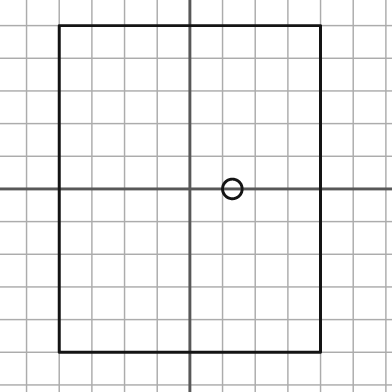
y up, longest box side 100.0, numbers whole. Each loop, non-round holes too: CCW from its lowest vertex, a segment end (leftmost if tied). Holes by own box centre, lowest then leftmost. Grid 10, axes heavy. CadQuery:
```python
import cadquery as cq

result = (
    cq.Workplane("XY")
    .moveTo(-40.0, -50.0)
    .lineTo(40.0, -50.0)
    .lineTo(40.0, 50.0)
    .lineTo(-40.0, 50.0)
    .close()
    .moveTo(13.0, 0.0)
    .circle(3.0)
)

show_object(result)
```